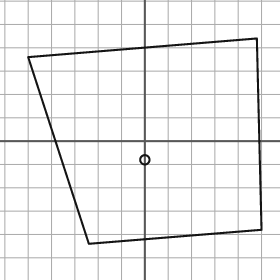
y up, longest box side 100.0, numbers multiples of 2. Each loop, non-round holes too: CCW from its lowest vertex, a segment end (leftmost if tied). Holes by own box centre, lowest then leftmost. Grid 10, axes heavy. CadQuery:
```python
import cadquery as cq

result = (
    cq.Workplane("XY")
    .moveTo(-24.0, -44.0)
    .lineTo(50.0, -38.0)
    .lineTo(48.0, 44.0)
    .lineTo(-50.0, 36.0)
    .close()
    .moveTo(0.0, -8.0)
    .circle(2.0)
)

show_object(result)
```